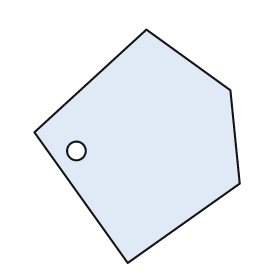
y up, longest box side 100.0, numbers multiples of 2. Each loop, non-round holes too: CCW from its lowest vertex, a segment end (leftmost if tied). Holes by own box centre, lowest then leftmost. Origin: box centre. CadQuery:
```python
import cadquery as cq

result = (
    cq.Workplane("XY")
    .moveTo(-4.0, -50.0)
    .lineTo(44.0, -16.0)
    .lineTo(40.0, 24.0)
    .lineTo(4.0, 50.0)
    .lineTo(-44.0, 6.0)
    .close()
    .moveTo(-26.0, -2.0)
    .circle(4.0)
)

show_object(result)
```